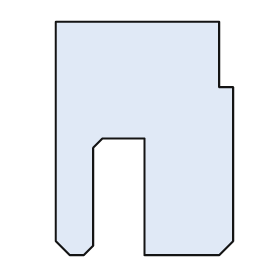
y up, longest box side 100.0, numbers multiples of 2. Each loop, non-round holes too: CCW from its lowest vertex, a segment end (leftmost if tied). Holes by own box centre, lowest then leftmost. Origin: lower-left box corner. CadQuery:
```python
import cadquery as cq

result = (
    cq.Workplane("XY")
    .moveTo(6.0, 0.0)
    .lineTo(12.0, 0.0)
    .lineTo(16.0, 4.0)
    .lineTo(16.0, 46.0)
    .lineTo(20.0, 50.0)
    .lineTo(38.0, 50.0)
    .lineTo(38.0, 0.0)
    .lineTo(70.0, 0.0)
    .lineTo(76.0, 6.0)
    .lineTo(76.0, 72.0)
    .lineTo(70.0, 72.0)
    .lineTo(70.0, 100.0)
    .lineTo(0.0, 100.0)
    .lineTo(0.0, 6.0)
    .close()
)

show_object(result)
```